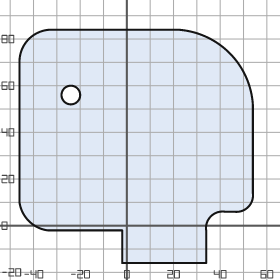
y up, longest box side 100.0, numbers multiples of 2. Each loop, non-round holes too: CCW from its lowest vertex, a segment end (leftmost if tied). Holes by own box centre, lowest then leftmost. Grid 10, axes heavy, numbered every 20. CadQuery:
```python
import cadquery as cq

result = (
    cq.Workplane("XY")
    .moveTo(-2.0, -16.0)
    .lineTo(34.0, -16.0)
    .lineTo(34.0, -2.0)
    .threePointArc((36.0, 4.0), (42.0, 6.0))
    .lineTo(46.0, 6.0)
    .threePointArc((52.0, 8.0), (54.0, 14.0))
    .lineTo(54.0, 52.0)
    .threePointArc((44.0, 74.0), (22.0, 84.0))
    .lineTo(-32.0, 84.0)
    .threePointArc((-42.0, 80.0), (-46.0, 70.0))
    .lineTo(-46.0, 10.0)
    .threePointArc((-42.0, 2.0), (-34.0, -2.0))
    .lineTo(-2.0, -2.0)
    .close()
    .moveTo(-24.0, 56.0)
    .circle(4.0)
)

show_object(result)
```